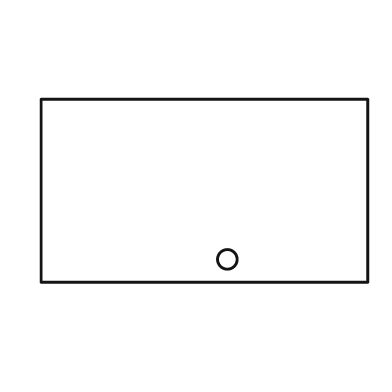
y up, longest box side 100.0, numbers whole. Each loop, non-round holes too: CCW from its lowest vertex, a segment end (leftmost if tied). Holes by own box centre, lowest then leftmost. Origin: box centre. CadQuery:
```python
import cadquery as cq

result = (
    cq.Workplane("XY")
    .moveTo(-50.0, -28.0)
    .lineTo(50.0, -28.0)
    .lineTo(50.0, 28.0)
    .lineTo(-50.0, 28.0)
    .close()
    .moveTo(7.0, -21.0)
    .circle(3.0)
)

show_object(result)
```